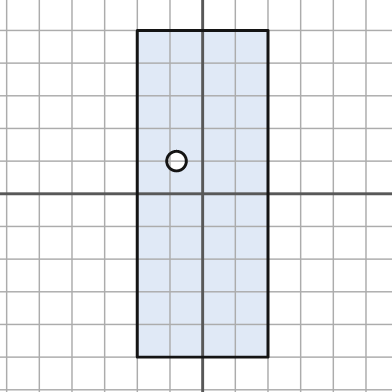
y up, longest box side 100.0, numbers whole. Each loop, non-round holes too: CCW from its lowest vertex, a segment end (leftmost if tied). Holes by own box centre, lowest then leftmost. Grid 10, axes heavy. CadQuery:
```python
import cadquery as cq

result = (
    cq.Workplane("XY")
    .moveTo(-20.0, -50.0)
    .lineTo(20.0, -50.0)
    .lineTo(20.0, 50.0)
    .lineTo(-20.0, 50.0)
    .close()
    .moveTo(-8.0, 10.0)
    .circle(3.0)
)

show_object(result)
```